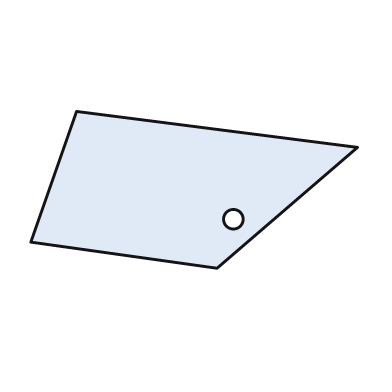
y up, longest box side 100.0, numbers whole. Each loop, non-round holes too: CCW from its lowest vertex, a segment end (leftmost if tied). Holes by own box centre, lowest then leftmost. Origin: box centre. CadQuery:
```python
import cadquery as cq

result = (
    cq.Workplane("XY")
    .moveTo(7.0, -24.0)
    .lineTo(50.0, 13.0)
    .lineTo(-36.0, 24.0)
    .lineTo(-50.0, -16.0)
    .close()
    .moveTo(12.0, -9.0)
    .circle(3.0)
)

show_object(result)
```